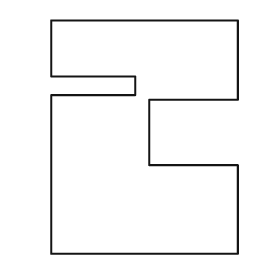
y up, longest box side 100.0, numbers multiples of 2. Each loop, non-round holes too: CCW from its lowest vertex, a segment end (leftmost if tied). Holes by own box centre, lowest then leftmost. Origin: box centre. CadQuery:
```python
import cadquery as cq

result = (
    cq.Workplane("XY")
    .moveTo(-40.0, -50.0)
    .lineTo(40.0, -50.0)
    .lineTo(40.0, -12.0)
    .lineTo(2.0, -12.0)
    .lineTo(2.0, 16.0)
    .lineTo(40.0, 16.0)
    .lineTo(40.0, 50.0)
    .lineTo(-40.0, 50.0)
    .lineTo(-40.0, 26.0)
    .lineTo(-4.0, 26.0)
    .lineTo(-4.0, 18.0)
    .lineTo(-40.0, 18.0)
    .close()
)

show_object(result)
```